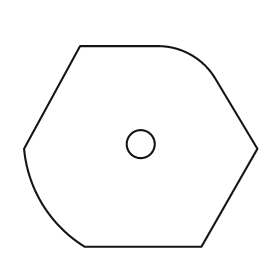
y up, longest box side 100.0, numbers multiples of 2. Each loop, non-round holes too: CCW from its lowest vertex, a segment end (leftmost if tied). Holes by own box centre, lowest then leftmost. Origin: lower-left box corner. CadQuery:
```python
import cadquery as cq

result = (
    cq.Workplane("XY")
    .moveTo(26.0, 0.0)
    .lineTo(76.0, 0.0)
    .lineTo(100.0, 42.0)
    .lineTo(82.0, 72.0)
    .threePointArc((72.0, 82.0), (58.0, 86.0))
    .lineTo(24.0, 86.0)
    .lineTo(0.0, 42.0)
    .threePointArc((8.0, 18.0), (26.0, 0.0))
    .close()
    .moveTo(50.0, 44.0)
    .circle(6.0)
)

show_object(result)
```